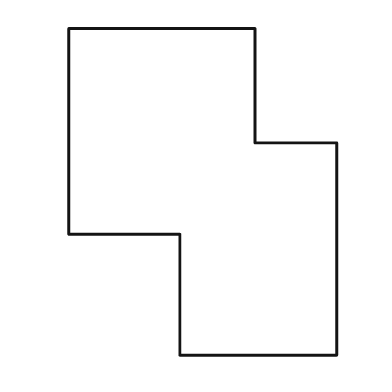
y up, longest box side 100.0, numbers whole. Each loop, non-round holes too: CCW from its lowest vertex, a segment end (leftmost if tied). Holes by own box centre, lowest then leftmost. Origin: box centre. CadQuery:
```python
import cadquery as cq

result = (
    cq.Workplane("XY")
    .moveTo(-7.0, -50.0)
    .lineTo(41.0, -50.0)
    .lineTo(41.0, 15.0)
    .lineTo(16.0, 15.0)
    .lineTo(16.0, 50.0)
    .lineTo(-41.0, 50.0)
    .lineTo(-41.0, -13.0)
    .lineTo(-7.0, -13.0)
    .close()
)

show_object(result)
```